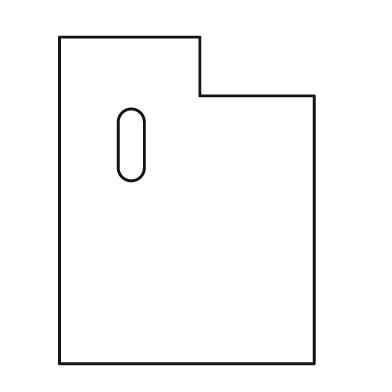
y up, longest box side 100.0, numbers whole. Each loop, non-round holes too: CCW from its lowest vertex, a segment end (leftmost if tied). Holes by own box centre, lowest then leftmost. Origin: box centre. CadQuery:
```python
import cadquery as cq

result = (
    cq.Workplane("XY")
    .moveTo(-39.0, -50.0)
    .lineTo(39.0, -50.0)
    .lineTo(39.0, 32.0)
    .lineTo(4.0, 32.0)
    .lineTo(4.0, 50.0)
    .lineTo(-39.0, 50.0)
    .close()
    .moveTo(-21.0, 10.0)
    .threePointArc((-17.0, 6.0), (-13.0, 10.0))
    .lineTo(-13.0, 24.0)
    .threePointArc((-17.0, 28.0), (-21.0, 24.0))
    .close()
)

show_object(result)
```